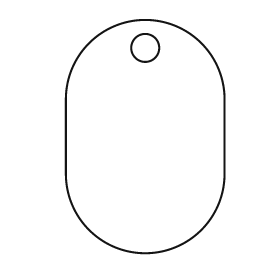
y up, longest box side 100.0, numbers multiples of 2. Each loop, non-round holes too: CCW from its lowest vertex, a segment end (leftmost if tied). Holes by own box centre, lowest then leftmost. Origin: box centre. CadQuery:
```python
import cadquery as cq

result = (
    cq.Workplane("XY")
    .moveTo(-34.0, -16.0)
    .threePointArc((0.0, -50.0), (34.0, -16.0))
    .lineTo(34.0, 16.0)
    .threePointArc((0.0, 50.0), (-34.0, 16.0))
    .close()
    .moveTo(0.0, 38.0)
    .circle(6.0)
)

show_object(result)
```